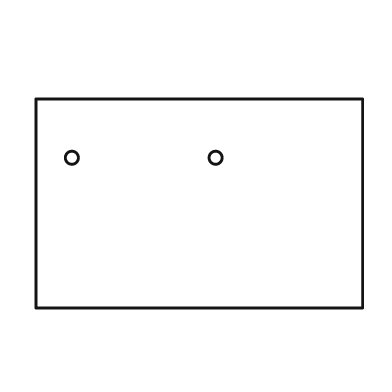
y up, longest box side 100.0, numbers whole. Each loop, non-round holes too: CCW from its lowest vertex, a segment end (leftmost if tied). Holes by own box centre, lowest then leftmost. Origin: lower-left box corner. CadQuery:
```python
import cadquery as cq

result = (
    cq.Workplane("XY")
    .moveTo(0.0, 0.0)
    .lineTo(100.0, 0.0)
    .lineTo(100.0, 64.0)
    .lineTo(0.0, 64.0)
    .close()
    .moveTo(11.0, 46.0)
    .circle(2.0)
    .moveTo(55.0, 46.0)
    .circle(2.0)
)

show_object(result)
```